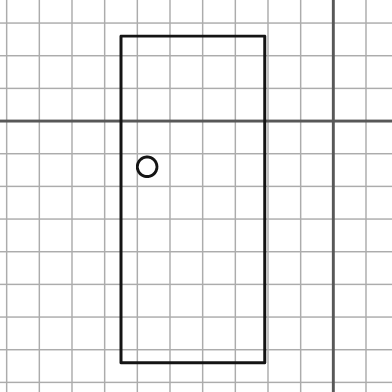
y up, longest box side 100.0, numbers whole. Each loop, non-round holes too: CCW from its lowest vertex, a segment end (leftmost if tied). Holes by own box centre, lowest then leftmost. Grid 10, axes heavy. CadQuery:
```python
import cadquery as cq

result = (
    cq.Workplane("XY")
    .moveTo(-65.0, -74.0)
    .lineTo(-21.0, -74.0)
    .lineTo(-21.0, 26.0)
    .lineTo(-65.0, 26.0)
    .close()
    .moveTo(-57.0, -14.0)
    .circle(3.0)
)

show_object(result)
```